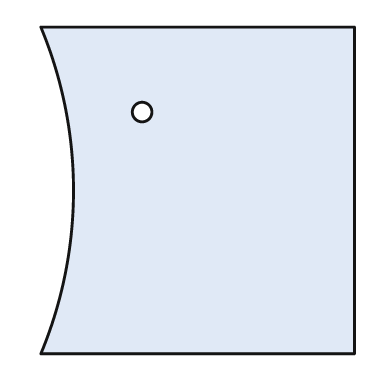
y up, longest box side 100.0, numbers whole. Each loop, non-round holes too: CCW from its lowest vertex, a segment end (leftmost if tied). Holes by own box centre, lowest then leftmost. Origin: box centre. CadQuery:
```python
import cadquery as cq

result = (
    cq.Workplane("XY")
    .moveTo(-48.0, -50.0)
    .lineTo(48.0, -50.0)
    .lineTo(48.0, 50.0)
    .lineTo(-48.0, 50.0)
    .threePointArc((-38.0, 0.0), (-48.0, -50.0))
    .close()
    .moveTo(-17.0, 24.0)
    .circle(3.0)
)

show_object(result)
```